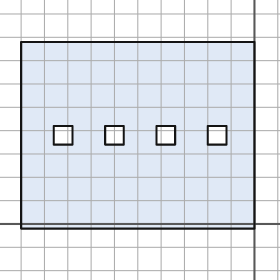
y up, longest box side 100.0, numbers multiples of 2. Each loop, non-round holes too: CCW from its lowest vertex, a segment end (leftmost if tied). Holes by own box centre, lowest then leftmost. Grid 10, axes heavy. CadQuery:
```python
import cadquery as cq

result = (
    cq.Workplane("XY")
    .moveTo(-100.0, -2.0)
    .lineTo(0.0, -2.0)
    .lineTo(0.0, 78.0)
    .lineTo(-100.0, 78.0)
    .close()
    .moveTo(-86.0, 34.0)
    .lineTo(-78.0, 34.0)
    .lineTo(-78.0, 42.0)
    .lineTo(-86.0, 42.0)
    .close()
    .moveTo(-64.0, 34.0)
    .lineTo(-56.0, 34.0)
    .lineTo(-56.0, 42.0)
    .lineTo(-64.0, 42.0)
    .close()
    .moveTo(-42.0, 34.0)
    .lineTo(-34.0, 34.0)
    .lineTo(-34.0, 42.0)
    .lineTo(-42.0, 42.0)
    .close()
    .moveTo(-20.0, 34.0)
    .lineTo(-12.0, 34.0)
    .lineTo(-12.0, 42.0)
    .lineTo(-20.0, 42.0)
    .close()
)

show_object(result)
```